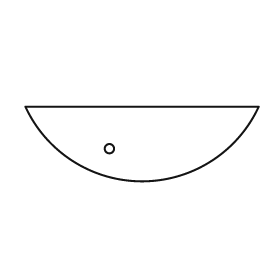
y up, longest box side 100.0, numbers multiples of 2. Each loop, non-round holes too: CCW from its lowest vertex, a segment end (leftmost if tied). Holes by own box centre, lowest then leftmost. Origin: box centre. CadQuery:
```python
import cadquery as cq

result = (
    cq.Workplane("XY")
    .moveTo(-50.0, 16.0)
    .threePointArc((0.0, -16.0), (50.0, 16.0))
    .close()
    .moveTo(-14.0, -2.0)
    .circle(2.0)
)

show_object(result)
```